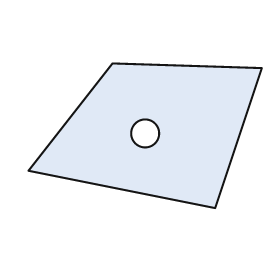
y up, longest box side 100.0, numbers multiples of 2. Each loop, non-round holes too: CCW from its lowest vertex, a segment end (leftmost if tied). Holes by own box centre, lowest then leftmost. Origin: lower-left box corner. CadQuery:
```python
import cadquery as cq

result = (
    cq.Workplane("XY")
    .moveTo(80.0, 0.0)
    .lineTo(100.0, 60.0)
    .lineTo(36.0, 62.0)
    .lineTo(0.0, 16.0)
    .close()
    .moveTo(50.0, 32.0)
    .circle(6.0)
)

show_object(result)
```